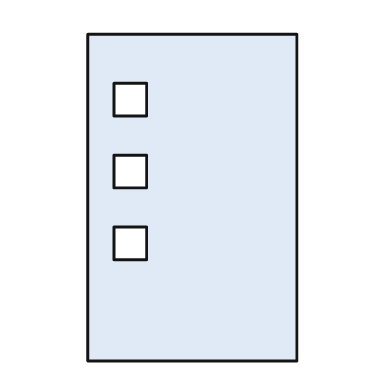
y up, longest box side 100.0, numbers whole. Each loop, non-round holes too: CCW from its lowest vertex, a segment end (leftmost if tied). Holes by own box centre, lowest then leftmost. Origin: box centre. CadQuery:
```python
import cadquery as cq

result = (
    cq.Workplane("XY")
    .moveTo(-32.0, -50.0)
    .lineTo(32.0, -50.0)
    .lineTo(32.0, 50.0)
    .lineTo(-32.0, 50.0)
    .close()
    .moveTo(-24.0, -19.0)
    .lineTo(-14.0, -19.0)
    .lineTo(-14.0, -9.0)
    .lineTo(-24.0, -9.0)
    .close()
    .moveTo(-24.0, 3.0)
    .lineTo(-14.0, 3.0)
    .lineTo(-14.0, 13.0)
    .lineTo(-24.0, 13.0)
    .close()
    .moveTo(-24.0, 25.0)
    .lineTo(-14.0, 25.0)
    .lineTo(-14.0, 35.0)
    .lineTo(-24.0, 35.0)
    .close()
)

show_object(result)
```